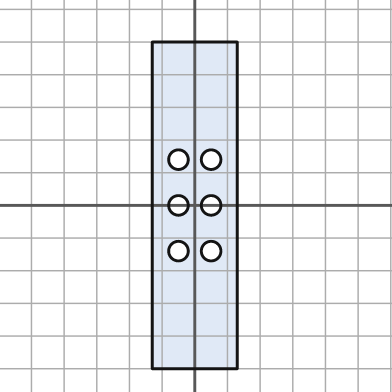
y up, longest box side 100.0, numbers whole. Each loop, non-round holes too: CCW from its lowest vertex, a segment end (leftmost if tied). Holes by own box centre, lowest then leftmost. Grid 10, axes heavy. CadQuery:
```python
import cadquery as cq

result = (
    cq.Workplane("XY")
    .moveTo(-13.0, -50.0)
    .lineTo(13.0, -50.0)
    .lineTo(13.0, 50.0)
    .lineTo(-13.0, 50.0)
    .close()
    .moveTo(-5.0, -14.0)
    .circle(3.0)
    .moveTo(5.0, -14.0)
    .circle(3.0)
    .moveTo(-5.0, 0.0)
    .circle(3.0)
    .moveTo(5.0, 0.0)
    .circle(3.0)
    .moveTo(-5.0, 14.0)
    .circle(3.0)
    .moveTo(5.0, 14.0)
    .circle(3.0)
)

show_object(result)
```